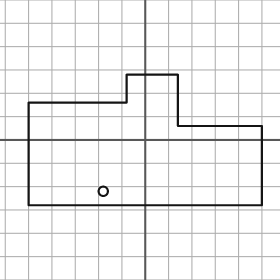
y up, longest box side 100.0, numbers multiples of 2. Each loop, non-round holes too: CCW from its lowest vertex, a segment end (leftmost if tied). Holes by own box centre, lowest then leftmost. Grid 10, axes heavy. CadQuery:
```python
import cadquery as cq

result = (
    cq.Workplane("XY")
    .moveTo(-50.0, -28.0)
    .lineTo(50.0, -28.0)
    .lineTo(50.0, 6.0)
    .lineTo(14.0, 6.0)
    .lineTo(14.0, 28.0)
    .lineTo(-8.0, 28.0)
    .lineTo(-8.0, 16.0)
    .lineTo(-50.0, 16.0)
    .close()
    .moveTo(-18.0, -22.0)
    .circle(2.0)
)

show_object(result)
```